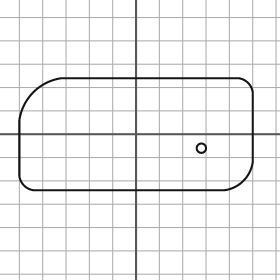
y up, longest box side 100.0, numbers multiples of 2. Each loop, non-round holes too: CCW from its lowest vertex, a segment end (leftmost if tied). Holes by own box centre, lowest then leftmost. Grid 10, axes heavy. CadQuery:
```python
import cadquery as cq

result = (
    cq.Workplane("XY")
    .moveTo(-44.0, -24.0)
    .lineTo(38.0, -24.0)
    .threePointArc((46.0, -20.0), (50.0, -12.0))
    .lineTo(50.0, 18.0)
    .threePointArc((48.0, 22.0), (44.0, 24.0))
    .lineTo(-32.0, 24.0)
    .threePointArc((-44.0, 18.0), (-50.0, 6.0))
    .lineTo(-50.0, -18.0)
    .threePointArc((-48.0, -22.0), (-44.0, -24.0))
    .close()
    .moveTo(28.0, -6.0)
    .circle(2.0)
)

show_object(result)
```